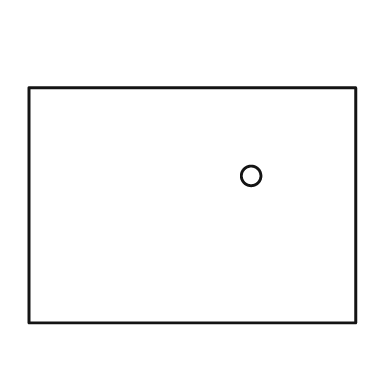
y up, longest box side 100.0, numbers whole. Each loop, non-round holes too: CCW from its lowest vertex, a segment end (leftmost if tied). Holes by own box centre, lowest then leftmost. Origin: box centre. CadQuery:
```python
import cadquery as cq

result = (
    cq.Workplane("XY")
    .moveTo(-50.0, -36.0)
    .lineTo(50.0, -36.0)
    .lineTo(50.0, 36.0)
    .lineTo(-50.0, 36.0)
    .close()
    .moveTo(18.0, 9.0)
    .circle(3.0)
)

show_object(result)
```